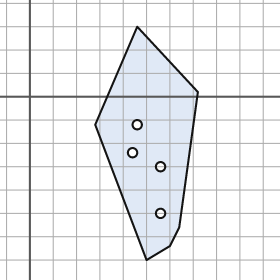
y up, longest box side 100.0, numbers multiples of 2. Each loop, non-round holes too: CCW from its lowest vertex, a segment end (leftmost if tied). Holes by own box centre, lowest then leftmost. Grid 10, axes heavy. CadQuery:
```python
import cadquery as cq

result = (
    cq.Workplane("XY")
    .moveTo(50.0, -70.0)
    .lineTo(60.0, -64.0)
    .lineTo(64.0, -56.0)
    .lineTo(72.0, 2.0)
    .lineTo(46.0, 30.0)
    .lineTo(28.0, -12.0)
    .close()
    .moveTo(56.0, -50.0)
    .circle(2.0)
    .moveTo(56.0, -30.0)
    .circle(2.0)
    .moveTo(44.0, -24.0)
    .circle(2.0)
    .moveTo(46.0, -12.0)
    .circle(2.0)
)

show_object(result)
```